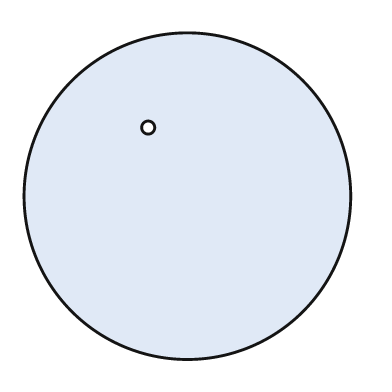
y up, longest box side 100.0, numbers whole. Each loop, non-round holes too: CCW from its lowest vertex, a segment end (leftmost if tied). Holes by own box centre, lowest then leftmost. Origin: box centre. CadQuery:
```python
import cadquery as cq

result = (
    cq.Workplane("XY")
    .moveTo(0.0, 0.0)
    .circle(50.0)
    .moveTo(-12.0, 21.0)
    .circle(2.0)
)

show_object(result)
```